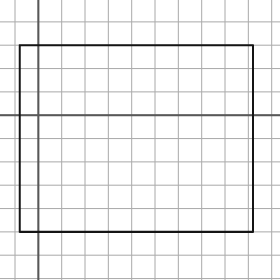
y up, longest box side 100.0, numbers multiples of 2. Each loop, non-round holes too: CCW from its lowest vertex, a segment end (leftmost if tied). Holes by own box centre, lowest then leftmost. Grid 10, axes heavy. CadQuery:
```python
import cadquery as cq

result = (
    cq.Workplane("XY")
    .moveTo(-8.0, -50.0)
    .lineTo(92.0, -50.0)
    .lineTo(92.0, 30.0)
    .lineTo(-8.0, 30.0)
    .close()
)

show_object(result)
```